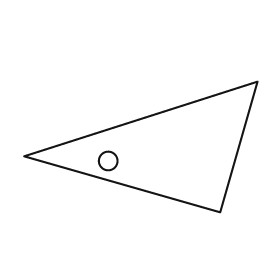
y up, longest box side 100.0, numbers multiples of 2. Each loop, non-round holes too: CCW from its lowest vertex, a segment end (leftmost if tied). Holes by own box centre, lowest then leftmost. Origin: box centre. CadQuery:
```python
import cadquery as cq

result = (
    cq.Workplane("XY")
    .moveTo(34.0, -28.0)
    .lineTo(50.0, 28.0)
    .lineTo(-50.0, -4.0)
    .close()
    .moveTo(-14.0, -6.0)
    .circle(4.0)
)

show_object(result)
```